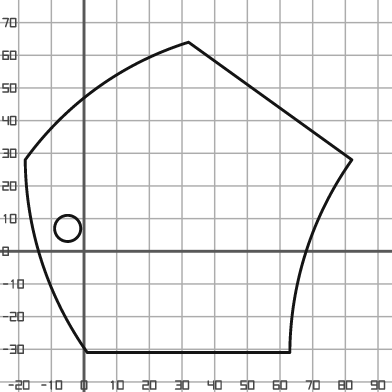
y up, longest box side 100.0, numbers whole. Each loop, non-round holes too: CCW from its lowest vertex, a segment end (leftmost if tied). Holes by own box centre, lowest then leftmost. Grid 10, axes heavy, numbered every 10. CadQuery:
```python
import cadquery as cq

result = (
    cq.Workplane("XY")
    .moveTo(1.0, -31.0)
    .lineTo(63.0, -31.0)
    .threePointArc((68.0, 0.0), (82.0, 28.0))
    .lineTo(32.0, 64.0)
    .threePointArc((4.0, 50.0), (-18.0, 28.0))
    .threePointArc((-13.0, -3.0), (1.0, -31.0))
    .close()
    .moveTo(-5.0, 7.0)
    .circle(4.0)
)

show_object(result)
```